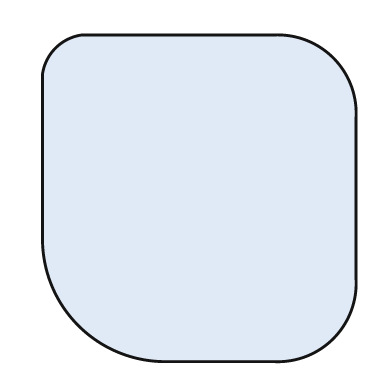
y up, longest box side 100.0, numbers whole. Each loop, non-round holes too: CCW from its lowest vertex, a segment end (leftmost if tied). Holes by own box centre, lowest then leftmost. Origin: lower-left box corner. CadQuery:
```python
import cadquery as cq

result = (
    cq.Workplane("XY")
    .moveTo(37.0, 0.0)
    .lineTo(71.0, 0.0)
    .threePointArc((89.0, 7.0), (96.0, 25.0))
    .lineTo(96.0, 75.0)
    .threePointArc((89.0, 93.0), (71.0, 100.0))
    .lineTo(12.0, 100.0)
    .threePointArc((4.0, 96.0), (0.0, 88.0))
    .lineTo(0.0, 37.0)
    .threePointArc((11.0, 11.0), (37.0, 0.0))
    .close()
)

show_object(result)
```